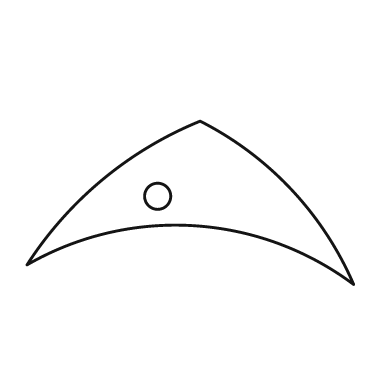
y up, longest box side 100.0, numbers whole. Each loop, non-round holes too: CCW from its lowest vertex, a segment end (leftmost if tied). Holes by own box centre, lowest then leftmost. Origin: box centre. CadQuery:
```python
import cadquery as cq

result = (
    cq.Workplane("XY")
    .moveTo(50.0, -25.0)
    .threePointArc((31.0, 4.0), (3.0, 25.0))
    .threePointArc((-27.0, 7.0), (-50.0, -19.0))
    .threePointArc((1.0, -7.0), (50.0, -25.0))
    .close()
    .moveTo(-10.0, 2.0)
    .circle(4.0)
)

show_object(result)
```